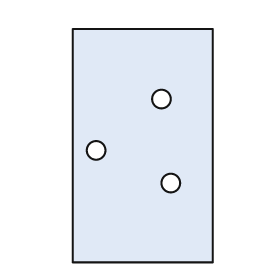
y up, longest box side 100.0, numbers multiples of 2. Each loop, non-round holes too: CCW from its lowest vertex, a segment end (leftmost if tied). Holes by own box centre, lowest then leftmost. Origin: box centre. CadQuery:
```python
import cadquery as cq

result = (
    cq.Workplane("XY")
    .moveTo(-30.0, -50.0)
    .lineTo(30.0, -50.0)
    .lineTo(30.0, 50.0)
    .lineTo(-30.0, 50.0)
    .close()
    .moveTo(12.0, -16.0)
    .circle(4.0)
    .moveTo(-20.0, -2.0)
    .circle(4.0)
    .moveTo(8.0, 20.0)
    .circle(4.0)
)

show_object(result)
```